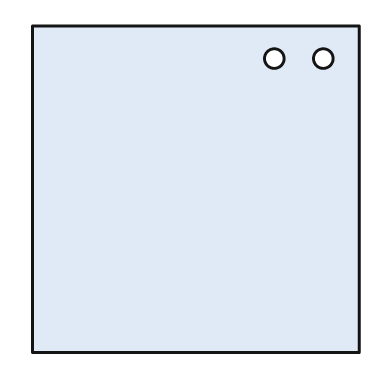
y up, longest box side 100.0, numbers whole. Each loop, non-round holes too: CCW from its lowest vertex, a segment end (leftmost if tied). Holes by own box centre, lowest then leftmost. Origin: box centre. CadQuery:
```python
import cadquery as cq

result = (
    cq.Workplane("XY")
    .moveTo(-50.0, -50.0)
    .lineTo(50.0, -50.0)
    .lineTo(50.0, 50.0)
    .lineTo(-50.0, 50.0)
    .close()
    .moveTo(24.0, 40.0)
    .circle(3.0)
    .moveTo(39.0, 40.0)
    .circle(3.0)
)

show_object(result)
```